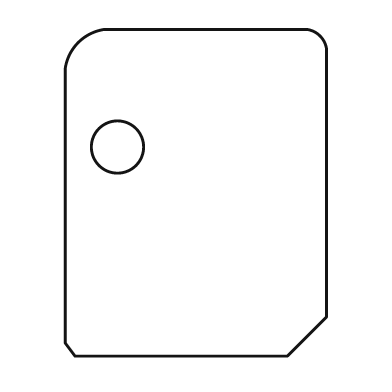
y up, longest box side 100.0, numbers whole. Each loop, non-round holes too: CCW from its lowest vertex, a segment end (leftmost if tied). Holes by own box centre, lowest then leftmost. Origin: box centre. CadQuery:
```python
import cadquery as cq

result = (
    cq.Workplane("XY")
    .moveTo(-37.0, -50.0)
    .lineTo(28.0, -50.0)
    .lineTo(40.0, -38.0)
    .lineTo(40.0, 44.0)
    .threePointArc((38.0, 48.0), (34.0, 50.0))
    .lineTo(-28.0, 50.0)
    .threePointArc((-36.0, 46.0), (-40.0, 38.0))
    .lineTo(-40.0, -46.0)
    .close()
    .moveTo(-24.0, 14.0)
    .circle(8.0)
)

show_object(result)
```